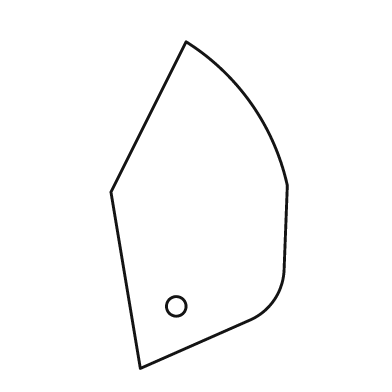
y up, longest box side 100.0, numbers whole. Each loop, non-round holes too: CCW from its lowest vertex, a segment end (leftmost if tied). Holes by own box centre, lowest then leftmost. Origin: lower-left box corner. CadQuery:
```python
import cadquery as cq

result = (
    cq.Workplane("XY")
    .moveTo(9.0, 0.0)
    .lineTo(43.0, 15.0)
    .threePointArc((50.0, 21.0), (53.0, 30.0))
    .lineTo(54.0, 56.0)
    .threePointArc((43.0, 81.0), (23.0, 100.0))
    .lineTo(0.0, 54.0)
    .close()
    .moveTo(20.0, 19.0)
    .circle(3.0)
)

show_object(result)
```